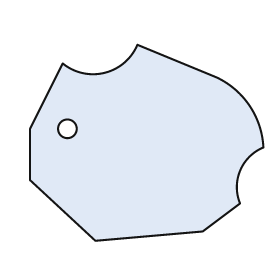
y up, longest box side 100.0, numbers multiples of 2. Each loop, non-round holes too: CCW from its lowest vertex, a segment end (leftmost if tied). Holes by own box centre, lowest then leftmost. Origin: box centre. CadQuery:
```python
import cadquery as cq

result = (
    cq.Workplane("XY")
    .moveTo(-22.0, -42.0)
    .lineTo(24.0, -38.0)
    .lineTo(40.0, -26.0)
    .threePointArc((40.0, -12.0), (50.0, -2.0))
    .threePointArc((44.0, 16.0), (30.0, 28.0))
    .lineTo(-4.0, 42.0)
    .threePointArc((-18.0, 30.0), (-36.0, 34.0))
    .lineTo(-50.0, 6.0)
    .lineTo(-50.0, -16.0)
    .close()
    .moveTo(-34.0, 6.0)
    .circle(4.0)
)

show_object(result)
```